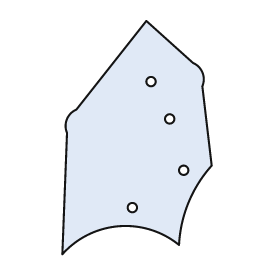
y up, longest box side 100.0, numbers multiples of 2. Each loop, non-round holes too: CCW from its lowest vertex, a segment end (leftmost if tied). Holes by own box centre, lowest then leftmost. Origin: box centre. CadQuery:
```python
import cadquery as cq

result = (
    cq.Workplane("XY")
    .moveTo(-32.0, -50.0)
    .threePointArc((-8.0, -38.0), (18.0, -46.0))
    .threePointArc((22.0, -28.0), (32.0, -12.0))
    .lineTo(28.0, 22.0)
    .threePointArc((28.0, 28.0), (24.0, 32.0))
    .lineTo(4.0, 50.0)
    .lineTo(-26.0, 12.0)
    .threePointArc((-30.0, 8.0), (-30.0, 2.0))
    .close()
    .moveTo(-2.0, -30.0)
    .circle(2.0)
    .moveTo(20.0, -14.0)
    .circle(2.0)
    .moveTo(14.0, 8.0)
    .circle(2.0)
    .moveTo(6.0, 24.0)
    .circle(2.0)
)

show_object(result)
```